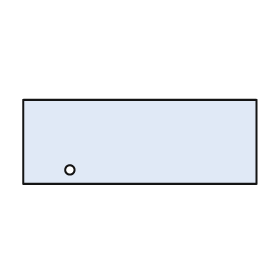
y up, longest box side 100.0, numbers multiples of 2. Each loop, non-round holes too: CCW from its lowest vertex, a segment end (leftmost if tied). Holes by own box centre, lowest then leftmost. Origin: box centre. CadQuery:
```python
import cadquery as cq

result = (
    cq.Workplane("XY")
    .moveTo(-50.0, -18.0)
    .lineTo(50.0, -18.0)
    .lineTo(50.0, 18.0)
    .lineTo(-50.0, 18.0)
    .close()
    .moveTo(-30.0, -12.0)
    .circle(2.0)
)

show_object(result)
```